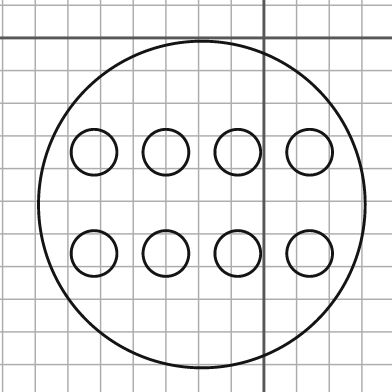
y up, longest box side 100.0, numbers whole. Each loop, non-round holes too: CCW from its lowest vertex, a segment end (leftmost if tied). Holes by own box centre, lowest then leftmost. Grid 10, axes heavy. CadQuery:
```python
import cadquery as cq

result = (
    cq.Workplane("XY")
    .moveTo(-19.0, -51.0)
    .circle(50.0)
    .moveTo(-52.0, -66.0)
    .circle(7.0)
    .moveTo(-30.0, -66.0)
    .circle(7.0)
    .moveTo(-8.0, -66.0)
    .circle(7.0)
    .moveTo(14.0, -66.0)
    .circle(7.0)
    .moveTo(-52.0, -35.0)
    .circle(7.0)
    .moveTo(-30.0, -35.0)
    .circle(7.0)
    .moveTo(-8.0, -35.0)
    .circle(7.0)
    .moveTo(14.0, -35.0)
    .circle(7.0)
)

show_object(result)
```